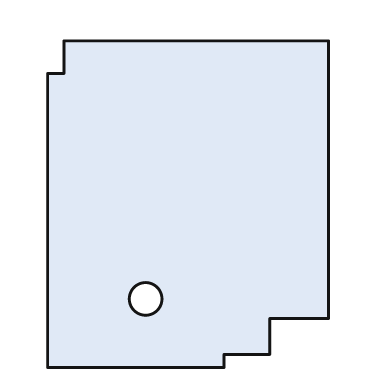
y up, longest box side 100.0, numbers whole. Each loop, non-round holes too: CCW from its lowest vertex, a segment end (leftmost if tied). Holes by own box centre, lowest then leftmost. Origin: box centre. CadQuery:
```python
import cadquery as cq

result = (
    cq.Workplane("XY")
    .moveTo(-43.0, -50.0)
    .lineTo(11.0, -50.0)
    .lineTo(11.0, -46.0)
    .lineTo(25.0, -46.0)
    .lineTo(25.0, -35.0)
    .lineTo(43.0, -35.0)
    .lineTo(43.0, 50.0)
    .lineTo(-38.0, 50.0)
    .lineTo(-38.0, 40.0)
    .lineTo(-43.0, 40.0)
    .close()
    .moveTo(-13.0, -29.0)
    .circle(5.0)
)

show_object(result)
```